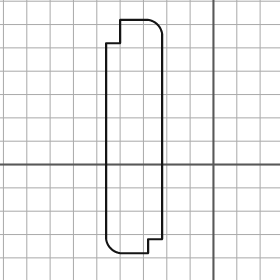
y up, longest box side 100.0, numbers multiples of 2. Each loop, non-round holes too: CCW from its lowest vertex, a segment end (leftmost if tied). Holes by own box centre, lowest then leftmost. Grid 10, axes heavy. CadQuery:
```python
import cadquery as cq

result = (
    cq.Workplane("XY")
    .moveTo(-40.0, -38.0)
    .lineTo(-28.0, -38.0)
    .lineTo(-28.0, -32.0)
    .lineTo(-22.0, -32.0)
    .lineTo(-22.0, 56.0)
    .threePointArc((-24.0, 60.0), (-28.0, 62.0))
    .lineTo(-40.0, 62.0)
    .lineTo(-40.0, 52.0)
    .lineTo(-46.0, 52.0)
    .lineTo(-46.0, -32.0)
    .threePointArc((-44.0, -36.0), (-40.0, -38.0))
    .close()
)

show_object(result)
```